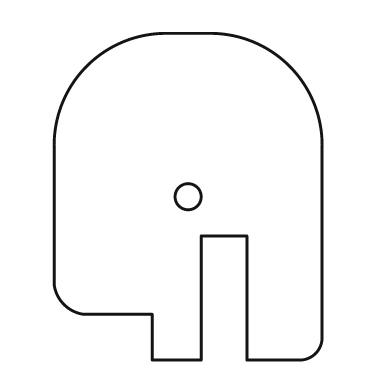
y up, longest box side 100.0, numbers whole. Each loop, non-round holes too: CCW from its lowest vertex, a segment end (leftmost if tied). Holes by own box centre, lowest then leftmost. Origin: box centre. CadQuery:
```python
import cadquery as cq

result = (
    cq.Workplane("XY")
    .moveTo(-11.0, -50.0)
    .lineTo(4.0, -50.0)
    .lineTo(4.0, -12.0)
    .lineTo(18.0, -12.0)
    .lineTo(18.0, -50.0)
    .lineTo(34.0, -50.0)
    .threePointArc((39.0, -48.0), (41.0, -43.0))
    .lineTo(41.0, 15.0)
    .threePointArc((31.0, 40.0), (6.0, 50.0))
    .lineTo(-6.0, 50.0)
    .threePointArc((-31.0, 40.0), (-41.0, 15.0))
    .lineTo(-41.0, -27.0)
    .threePointArc((-38.0, -33.0), (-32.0, -36.0))
    .lineTo(-11.0, -36.0)
    .close()
    .moveTo(0.0, 0.0)
    .circle(4.0)
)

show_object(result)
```